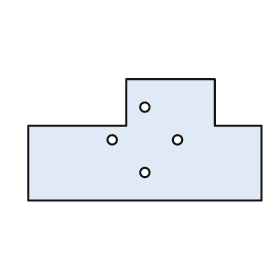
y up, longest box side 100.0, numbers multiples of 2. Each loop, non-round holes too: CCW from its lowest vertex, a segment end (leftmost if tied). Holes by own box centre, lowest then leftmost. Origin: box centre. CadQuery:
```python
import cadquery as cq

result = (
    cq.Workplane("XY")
    .moveTo(-50.0, -26.0)
    .lineTo(50.0, -26.0)
    .lineTo(50.0, 6.0)
    .lineTo(30.0, 6.0)
    .lineTo(30.0, 26.0)
    .lineTo(-8.0, 26.0)
    .lineTo(-8.0, 6.0)
    .lineTo(-50.0, 6.0)
    .close()
    .moveTo(0.0, -14.0)
    .circle(2.0)
    .moveTo(-14.0, 0.0)
    .circle(2.0)
    .moveTo(14.0, 0.0)
    .circle(2.0)
    .moveTo(0.0, 14.0)
    .circle(2.0)
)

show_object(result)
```